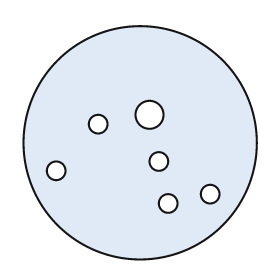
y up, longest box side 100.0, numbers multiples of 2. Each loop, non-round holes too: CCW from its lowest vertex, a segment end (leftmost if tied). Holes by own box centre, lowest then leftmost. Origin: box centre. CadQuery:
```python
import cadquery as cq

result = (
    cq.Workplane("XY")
    .moveTo(0.0, 0.0)
    .circle(50.0)
    .moveTo(12.0, -26.0)
    .circle(4.0)
    .moveTo(30.0, -22.0)
    .circle(4.0)
    .moveTo(-36.0, -12.0)
    .circle(4.0)
    .moveTo(8.0, -8.0)
    .circle(4.0)
    .moveTo(-18.0, 8.0)
    .circle(4.0)
    .moveTo(4.0, 12.0)
    .circle(6.0)
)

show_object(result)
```